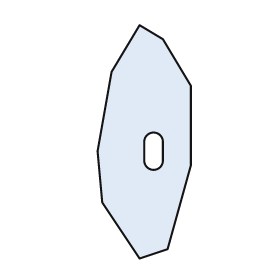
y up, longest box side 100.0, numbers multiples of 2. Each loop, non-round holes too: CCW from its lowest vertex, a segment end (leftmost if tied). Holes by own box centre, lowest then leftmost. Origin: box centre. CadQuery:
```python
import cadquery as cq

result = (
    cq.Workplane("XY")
    .moveTo(-2.0, -50.0)
    .lineTo(10.0, -46.0)
    .lineTo(20.0, -10.0)
    .lineTo(20.0, 24.0)
    .lineTo(8.0, 44.0)
    .lineTo(-2.0, 50.0)
    .lineTo(-14.0, 30.0)
    .lineTo(-20.0, -4.0)
    .lineTo(-18.0, -26.0)
    .close()
    .moveTo(0.0, -8.0)
    .threePointArc((4.0, -12.0), (8.0, -8.0))
    .lineTo(8.0, 0.0)
    .threePointArc((4.0, 4.0), (0.0, 0.0))
    .close()
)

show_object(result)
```